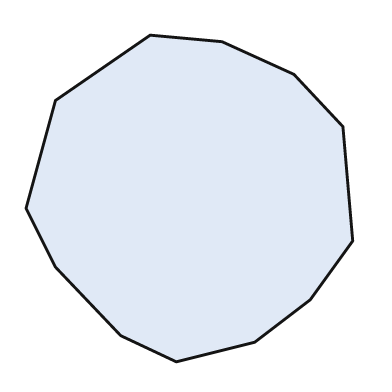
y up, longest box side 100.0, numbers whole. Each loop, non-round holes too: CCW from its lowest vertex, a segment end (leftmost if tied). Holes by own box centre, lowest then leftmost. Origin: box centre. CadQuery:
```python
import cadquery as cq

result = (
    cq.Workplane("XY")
    .moveTo(-4.0, -50.0)
    .lineTo(20.0, -44.0)
    .lineTo(37.0, -31.0)
    .lineTo(50.0, -13.0)
    .lineTo(47.0, 22.0)
    .lineTo(32.0, 38.0)
    .lineTo(10.0, 48.0)
    .lineTo(-12.0, 50.0)
    .lineTo(-41.0, 30.0)
    .lineTo(-50.0, -3.0)
    .lineTo(-41.0, -21.0)
    .lineTo(-21.0, -42.0)
    .close()
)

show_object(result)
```